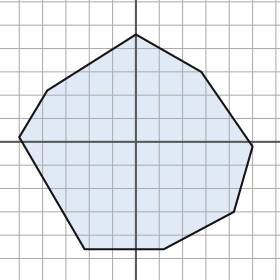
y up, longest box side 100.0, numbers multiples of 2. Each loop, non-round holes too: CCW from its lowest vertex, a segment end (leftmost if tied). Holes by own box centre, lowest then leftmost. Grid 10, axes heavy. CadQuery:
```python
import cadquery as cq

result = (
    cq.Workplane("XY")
    .moveTo(-22.0, -46.0)
    .lineTo(12.0, -46.0)
    .lineTo(42.0, -30.0)
    .lineTo(50.0, -2.0)
    .lineTo(28.0, 30.0)
    .lineTo(0.0, 46.0)
    .lineTo(-38.0, 22.0)
    .lineTo(-50.0, 2.0)
    .close()
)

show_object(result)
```